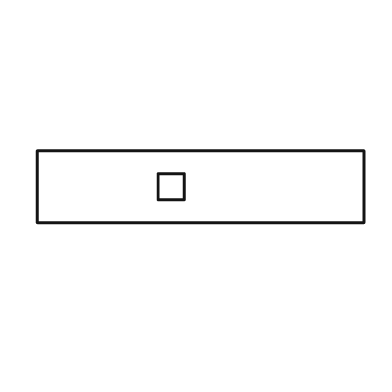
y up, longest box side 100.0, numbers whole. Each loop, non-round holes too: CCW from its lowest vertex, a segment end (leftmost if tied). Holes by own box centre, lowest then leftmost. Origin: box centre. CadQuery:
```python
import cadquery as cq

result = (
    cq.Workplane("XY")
    .moveTo(-50.0, -11.0)
    .lineTo(50.0, -11.0)
    .lineTo(50.0, 11.0)
    .lineTo(-50.0, 11.0)
    .close()
    .moveTo(-13.0, -4.0)
    .lineTo(-5.0, -4.0)
    .lineTo(-5.0, 4.0)
    .lineTo(-13.0, 4.0)
    .close()
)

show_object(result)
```